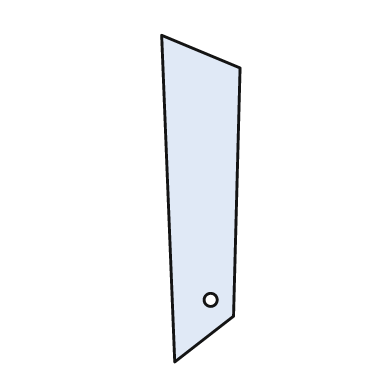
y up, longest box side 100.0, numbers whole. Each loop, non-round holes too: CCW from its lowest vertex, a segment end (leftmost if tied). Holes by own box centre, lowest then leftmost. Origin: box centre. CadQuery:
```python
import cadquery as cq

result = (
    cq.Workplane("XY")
    .moveTo(-8.0, -50.0)
    .lineTo(10.0, -36.0)
    .lineTo(12.0, 40.0)
    .lineTo(-12.0, 50.0)
    .close()
    .moveTo(3.0, -31.0)
    .circle(2.0)
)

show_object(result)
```